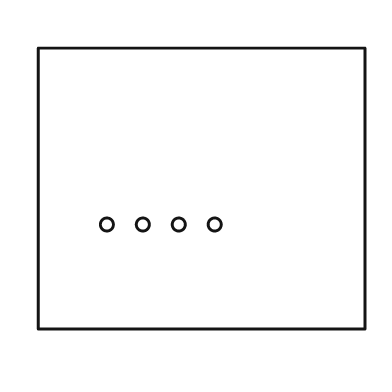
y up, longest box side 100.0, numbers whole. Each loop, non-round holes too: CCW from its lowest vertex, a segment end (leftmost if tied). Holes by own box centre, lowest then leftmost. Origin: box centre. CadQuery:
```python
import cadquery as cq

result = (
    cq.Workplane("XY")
    .moveTo(-50.0, -43.0)
    .lineTo(50.0, -43.0)
    .lineTo(50.0, 43.0)
    .lineTo(-50.0, 43.0)
    .close()
    .moveTo(-29.0, -11.0)
    .circle(2.0)
    .moveTo(-18.0, -11.0)
    .circle(2.0)
    .moveTo(-7.0, -11.0)
    .circle(2.0)
    .moveTo(4.0, -11.0)
    .circle(2.0)
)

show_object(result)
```